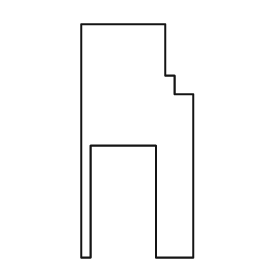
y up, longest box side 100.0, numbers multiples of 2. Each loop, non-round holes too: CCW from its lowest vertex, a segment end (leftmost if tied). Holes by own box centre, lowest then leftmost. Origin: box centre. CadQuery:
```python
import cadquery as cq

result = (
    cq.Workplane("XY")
    .moveTo(-24.0, -50.0)
    .lineTo(-20.0, -50.0)
    .lineTo(-20.0, -2.0)
    .lineTo(8.0, -2.0)
    .lineTo(8.0, -50.0)
    .lineTo(24.0, -50.0)
    .lineTo(24.0, 20.0)
    .lineTo(16.0, 20.0)
    .lineTo(16.0, 28.0)
    .lineTo(12.0, 28.0)
    .lineTo(12.0, 50.0)
    .lineTo(-24.0, 50.0)
    .close()
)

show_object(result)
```